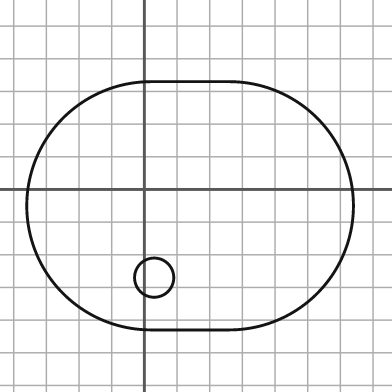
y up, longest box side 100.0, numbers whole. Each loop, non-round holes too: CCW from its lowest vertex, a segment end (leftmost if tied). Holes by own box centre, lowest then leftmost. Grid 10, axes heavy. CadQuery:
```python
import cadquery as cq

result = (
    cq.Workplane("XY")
    .moveTo(2.0, -43.0)
    .lineTo(26.0, -43.0)
    .threePointArc((64.0, -5.0), (26.0, 33.0))
    .lineTo(2.0, 33.0)
    .threePointArc((-36.0, -5.0), (2.0, -43.0))
    .close()
    .moveTo(3.0, -27.0)
    .circle(6.0)
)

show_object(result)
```